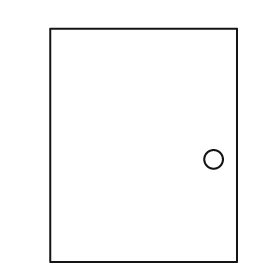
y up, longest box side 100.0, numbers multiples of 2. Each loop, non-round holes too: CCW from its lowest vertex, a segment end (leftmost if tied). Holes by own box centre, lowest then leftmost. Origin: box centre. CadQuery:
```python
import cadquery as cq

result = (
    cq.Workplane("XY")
    .moveTo(-40.0, -50.0)
    .lineTo(40.0, -50.0)
    .lineTo(40.0, 50.0)
    .lineTo(-40.0, 50.0)
    .close()
    .moveTo(30.0, -6.0)
    .circle(4.0)
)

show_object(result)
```